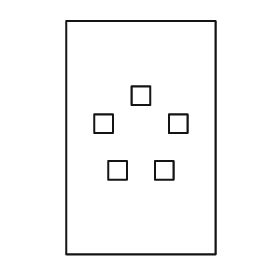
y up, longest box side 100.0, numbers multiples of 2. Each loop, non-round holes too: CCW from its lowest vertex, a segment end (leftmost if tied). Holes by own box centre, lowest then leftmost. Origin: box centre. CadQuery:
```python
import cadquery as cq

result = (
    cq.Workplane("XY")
    .moveTo(-32.0, -50.0)
    .lineTo(32.0, -50.0)
    .lineTo(32.0, 50.0)
    .lineTo(-32.0, 50.0)
    .close()
    .moveTo(-14.0, -18.0)
    .lineTo(-6.0, -18.0)
    .lineTo(-6.0, -10.0)
    .lineTo(-14.0, -10.0)
    .close()
    .moveTo(6.0, -18.0)
    .lineTo(14.0, -18.0)
    .lineTo(14.0, -10.0)
    .lineTo(6.0, -10.0)
    .close()
    .moveTo(-20.0, 2.0)
    .lineTo(-12.0, 2.0)
    .lineTo(-12.0, 10.0)
    .lineTo(-20.0, 10.0)
    .close()
    .moveTo(12.0, 2.0)
    .lineTo(20.0, 2.0)
    .lineTo(20.0, 10.0)
    .lineTo(12.0, 10.0)
    .close()
    .moveTo(-4.0, 14.0)
    .lineTo(4.0, 14.0)
    .lineTo(4.0, 22.0)
    .lineTo(-4.0, 22.0)
    .close()
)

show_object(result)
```